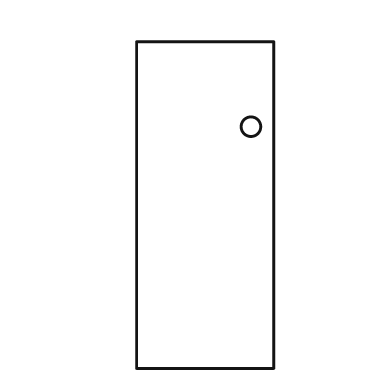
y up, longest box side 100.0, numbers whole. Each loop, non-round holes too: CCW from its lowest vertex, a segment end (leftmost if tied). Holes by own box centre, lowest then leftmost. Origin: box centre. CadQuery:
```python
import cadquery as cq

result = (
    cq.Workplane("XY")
    .moveTo(-21.0, -50.0)
    .lineTo(21.0, -50.0)
    .lineTo(21.0, 50.0)
    .lineTo(-21.0, 50.0)
    .close()
    .moveTo(14.0, 24.0)
    .circle(3.0)
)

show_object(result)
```